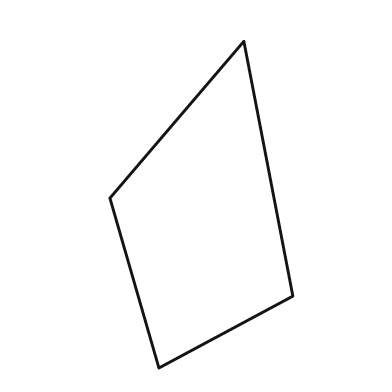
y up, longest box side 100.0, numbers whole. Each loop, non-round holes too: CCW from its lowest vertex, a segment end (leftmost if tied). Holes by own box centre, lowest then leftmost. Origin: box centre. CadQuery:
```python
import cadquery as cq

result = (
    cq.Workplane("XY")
    .moveTo(-13.0, -50.0)
    .lineTo(28.0, -28.0)
    .lineTo(13.0, 50.0)
    .lineTo(-28.0, 2.0)
    .close()
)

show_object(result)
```